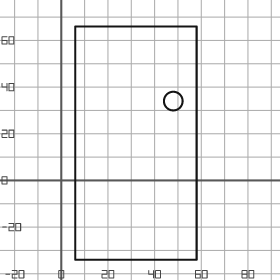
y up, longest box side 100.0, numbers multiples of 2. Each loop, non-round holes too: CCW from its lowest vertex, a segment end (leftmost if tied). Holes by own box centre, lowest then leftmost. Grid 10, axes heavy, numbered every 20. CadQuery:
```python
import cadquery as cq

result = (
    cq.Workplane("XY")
    .moveTo(6.0, -34.0)
    .lineTo(58.0, -34.0)
    .lineTo(58.0, 66.0)
    .lineTo(6.0, 66.0)
    .close()
    .moveTo(48.0, 34.0)
    .circle(4.0)
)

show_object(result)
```